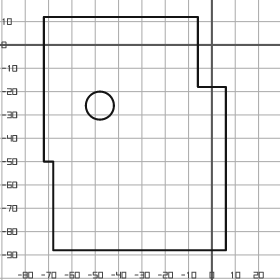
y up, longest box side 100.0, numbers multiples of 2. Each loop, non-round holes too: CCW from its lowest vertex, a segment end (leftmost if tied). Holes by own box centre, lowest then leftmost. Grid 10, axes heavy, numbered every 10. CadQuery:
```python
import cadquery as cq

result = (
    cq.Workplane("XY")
    .moveTo(-68.0, -88.0)
    .lineTo(6.0, -88.0)
    .lineTo(6.0, -18.0)
    .lineTo(-6.0, -18.0)
    .lineTo(-6.0, 12.0)
    .lineTo(-72.0, 12.0)
    .lineTo(-72.0, -50.0)
    .lineTo(-68.0, -50.0)
    .close()
    .moveTo(-48.0, -26.0)
    .circle(6.0)
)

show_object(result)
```